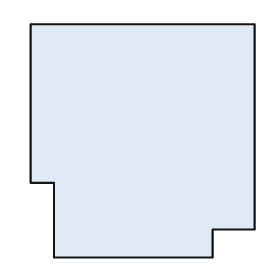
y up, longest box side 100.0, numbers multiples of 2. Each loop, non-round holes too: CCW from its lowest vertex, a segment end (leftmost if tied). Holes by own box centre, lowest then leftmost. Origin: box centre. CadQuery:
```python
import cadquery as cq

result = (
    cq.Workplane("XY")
    .moveTo(-38.0, -50.0)
    .lineTo(30.0, -50.0)
    .lineTo(30.0, -38.0)
    .lineTo(48.0, -38.0)
    .lineTo(48.0, 50.0)
    .lineTo(-48.0, 50.0)
    .lineTo(-48.0, -18.0)
    .lineTo(-38.0, -18.0)
    .close()
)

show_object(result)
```